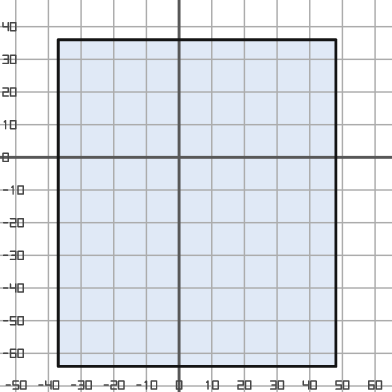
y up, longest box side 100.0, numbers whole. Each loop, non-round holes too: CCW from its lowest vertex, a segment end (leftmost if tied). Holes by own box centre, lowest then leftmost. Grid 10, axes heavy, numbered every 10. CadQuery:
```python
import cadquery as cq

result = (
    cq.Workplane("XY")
    .moveTo(-37.0, -64.0)
    .lineTo(48.0, -64.0)
    .lineTo(48.0, 36.0)
    .lineTo(-37.0, 36.0)
    .close()
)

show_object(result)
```